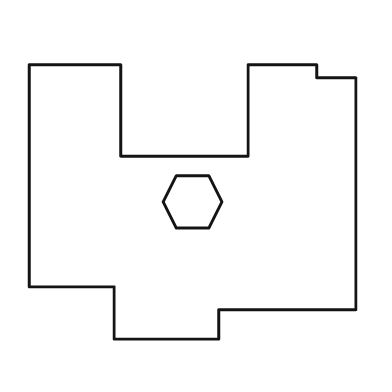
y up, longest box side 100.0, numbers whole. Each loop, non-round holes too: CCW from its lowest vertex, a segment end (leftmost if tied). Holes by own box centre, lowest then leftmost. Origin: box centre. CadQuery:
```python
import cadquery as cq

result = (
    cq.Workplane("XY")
    .moveTo(-24.0, -42.0)
    .lineTo(8.0, -42.0)
    .lineTo(8.0, -33.0)
    .lineTo(50.0, -33.0)
    .lineTo(50.0, 38.0)
    .lineTo(38.0, 38.0)
    .lineTo(38.0, 42.0)
    .lineTo(17.0, 42.0)
    .lineTo(17.0, 14.0)
    .lineTo(-22.0, 14.0)
    .lineTo(-22.0, 42.0)
    .lineTo(-50.0, 42.0)
    .lineTo(-50.0, -26.0)
    .lineTo(-24.0, -26.0)
    .close()
    .moveTo(-5.0, -8.0)
    .lineTo(5.0, -8.0)
    .lineTo(9.0, 0.0)
    .lineTo(5.0, 8.0)
    .lineTo(-5.0, 8.0)
    .lineTo(-9.0, 0.0)
    .close()
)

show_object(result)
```